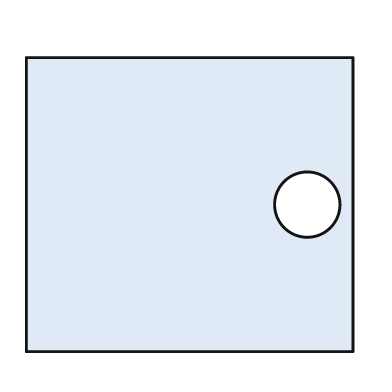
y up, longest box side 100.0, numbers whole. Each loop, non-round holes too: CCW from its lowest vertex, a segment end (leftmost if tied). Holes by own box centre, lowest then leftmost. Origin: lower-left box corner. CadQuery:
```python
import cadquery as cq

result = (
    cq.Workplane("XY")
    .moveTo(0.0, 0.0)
    .lineTo(100.0, 0.0)
    .lineTo(100.0, 90.0)
    .lineTo(0.0, 90.0)
    .close()
    .moveTo(86.0, 45.0)
    .circle(10.0)
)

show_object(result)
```